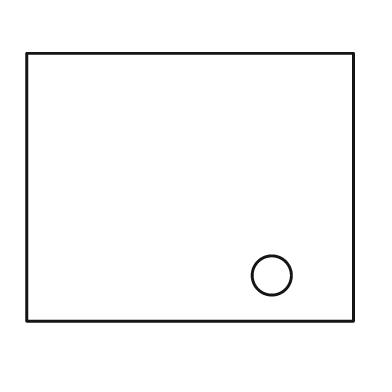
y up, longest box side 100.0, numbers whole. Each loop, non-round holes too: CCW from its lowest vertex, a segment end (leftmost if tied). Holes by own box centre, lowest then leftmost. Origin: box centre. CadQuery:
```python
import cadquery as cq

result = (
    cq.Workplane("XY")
    .moveTo(-50.0, -41.0)
    .lineTo(50.0, -41.0)
    .lineTo(50.0, 41.0)
    .lineTo(-50.0, 41.0)
    .close()
    .moveTo(25.0, -27.0)
    .circle(6.0)
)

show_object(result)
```